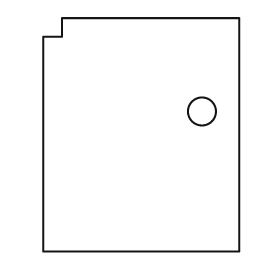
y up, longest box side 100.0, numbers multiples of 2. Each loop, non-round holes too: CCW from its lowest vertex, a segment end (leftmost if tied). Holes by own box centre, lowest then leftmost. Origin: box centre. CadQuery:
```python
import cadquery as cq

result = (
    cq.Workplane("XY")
    .moveTo(-42.0, -50.0)
    .lineTo(42.0, -50.0)
    .lineTo(42.0, 50.0)
    .lineTo(-34.0, 50.0)
    .lineTo(-34.0, 42.0)
    .lineTo(-42.0, 42.0)
    .close()
    .moveTo(26.0, 10.0)
    .circle(6.0)
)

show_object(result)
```